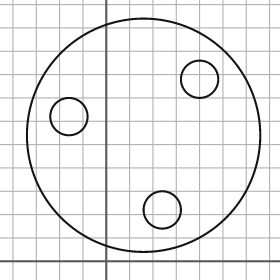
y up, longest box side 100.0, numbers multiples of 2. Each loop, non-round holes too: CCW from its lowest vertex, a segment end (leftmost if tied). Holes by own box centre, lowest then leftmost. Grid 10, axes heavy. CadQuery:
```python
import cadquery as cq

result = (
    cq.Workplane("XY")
    .moveTo(16.0, 54.0)
    .circle(50.0)
    .moveTo(24.0, 22.0)
    .circle(8.0)
    .moveTo(-16.0, 62.0)
    .circle(8.0)
    .moveTo(40.0, 78.0)
    .circle(8.0)
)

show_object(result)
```